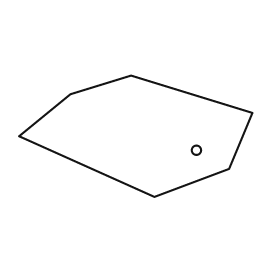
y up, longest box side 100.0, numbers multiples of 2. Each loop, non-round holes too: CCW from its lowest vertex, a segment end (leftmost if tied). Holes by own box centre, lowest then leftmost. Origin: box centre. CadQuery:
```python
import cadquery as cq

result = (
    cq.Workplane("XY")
    .moveTo(8.0, -26.0)
    .lineTo(40.0, -14.0)
    .lineTo(50.0, 10.0)
    .lineTo(-2.0, 26.0)
    .lineTo(-28.0, 18.0)
    .lineTo(-50.0, 0.0)
    .close()
    .moveTo(26.0, -6.0)
    .circle(2.0)
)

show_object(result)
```